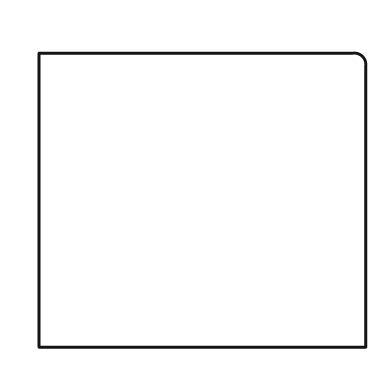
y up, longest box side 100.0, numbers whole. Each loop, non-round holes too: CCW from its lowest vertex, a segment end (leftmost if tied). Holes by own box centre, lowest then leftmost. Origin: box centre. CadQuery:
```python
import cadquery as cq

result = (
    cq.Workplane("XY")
    .moveTo(-50.0, -45.0)
    .lineTo(50.0, -45.0)
    .lineTo(50.0, 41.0)
    .threePointArc((49.0, 44.0), (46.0, 45.0))
    .lineTo(-50.0, 45.0)
    .close()
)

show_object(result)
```